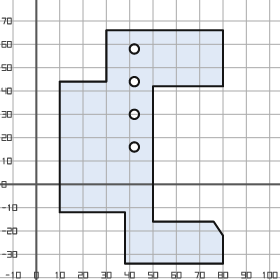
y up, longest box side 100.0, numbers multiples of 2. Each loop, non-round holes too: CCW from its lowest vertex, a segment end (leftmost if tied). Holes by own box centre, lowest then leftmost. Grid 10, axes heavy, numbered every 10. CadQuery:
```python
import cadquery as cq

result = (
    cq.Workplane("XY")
    .moveTo(38.0, -34.0)
    .lineTo(80.0, -34.0)
    .lineTo(80.0, -22.0)
    .lineTo(76.0, -16.0)
    .lineTo(50.0, -16.0)
    .lineTo(50.0, 42.0)
    .lineTo(80.0, 42.0)
    .lineTo(80.0, 66.0)
    .lineTo(30.0, 66.0)
    .lineTo(30.0, 44.0)
    .lineTo(10.0, 44.0)
    .lineTo(10.0, -12.0)
    .lineTo(38.0, -12.0)
    .close()
    .moveTo(42.0, 16.0)
    .circle(2.0)
    .moveTo(42.0, 30.0)
    .circle(2.0)
    .moveTo(42.0, 44.0)
    .circle(2.0)
    .moveTo(42.0, 58.0)
    .circle(2.0)
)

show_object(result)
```